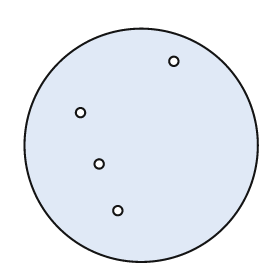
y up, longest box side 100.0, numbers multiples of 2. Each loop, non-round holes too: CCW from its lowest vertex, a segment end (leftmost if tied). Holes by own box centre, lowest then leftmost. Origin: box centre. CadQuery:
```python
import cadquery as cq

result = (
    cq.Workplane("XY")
    .moveTo(0.0, 0.0)
    .circle(50.0)
    .moveTo(-10.0, -28.0)
    .circle(2.0)
    .moveTo(-18.0, -8.0)
    .circle(2.0)
    .moveTo(-26.0, 14.0)
    .circle(2.0)
    .moveTo(14.0, 36.0)
    .circle(2.0)
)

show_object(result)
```